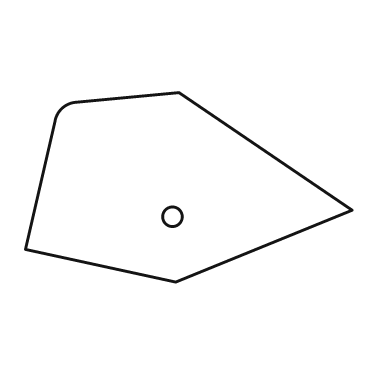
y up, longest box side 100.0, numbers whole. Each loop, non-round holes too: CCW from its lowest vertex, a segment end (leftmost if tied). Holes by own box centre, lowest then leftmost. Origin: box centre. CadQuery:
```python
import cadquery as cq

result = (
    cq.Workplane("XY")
    .moveTo(-4.0, -29.0)
    .lineTo(50.0, -7.0)
    .lineTo(-3.0, 29.0)
    .lineTo(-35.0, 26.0)
    .threePointArc((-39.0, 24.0), (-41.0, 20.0))
    .lineTo(-50.0, -19.0)
    .close()
    .moveTo(-5.0, -9.0)
    .circle(3.0)
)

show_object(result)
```